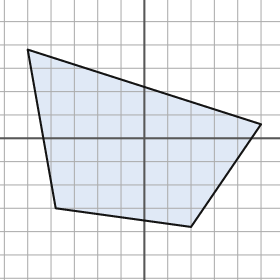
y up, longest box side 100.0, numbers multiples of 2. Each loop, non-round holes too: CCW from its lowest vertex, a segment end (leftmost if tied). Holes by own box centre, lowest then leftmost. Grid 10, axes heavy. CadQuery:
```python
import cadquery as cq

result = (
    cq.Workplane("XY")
    .moveTo(20.0, -38.0)
    .lineTo(50.0, 6.0)
    .lineTo(-50.0, 38.0)
    .lineTo(-38.0, -30.0)
    .close()
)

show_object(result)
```